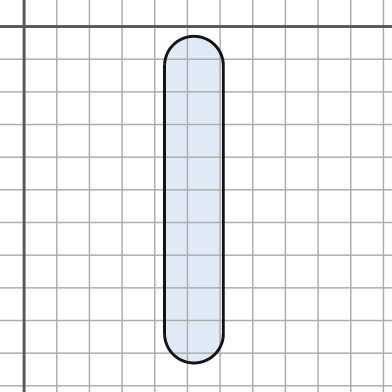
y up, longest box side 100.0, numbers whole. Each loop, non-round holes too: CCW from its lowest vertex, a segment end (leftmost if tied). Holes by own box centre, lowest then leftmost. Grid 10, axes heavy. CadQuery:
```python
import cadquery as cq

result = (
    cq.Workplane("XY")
    .moveTo(43.0, -94.0)
    .threePointArc((52.0, -103.0), (61.0, -94.0))
    .lineTo(61.0, -12.0)
    .threePointArc((52.0, -3.0), (43.0, -12.0))
    .close()
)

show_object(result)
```